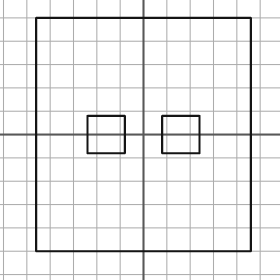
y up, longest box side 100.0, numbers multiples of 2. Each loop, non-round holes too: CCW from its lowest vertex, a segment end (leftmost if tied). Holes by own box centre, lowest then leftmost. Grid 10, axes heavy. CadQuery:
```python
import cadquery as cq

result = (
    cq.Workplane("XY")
    .moveTo(-46.0, -50.0)
    .lineTo(46.0, -50.0)
    .lineTo(46.0, 50.0)
    .lineTo(-46.0, 50.0)
    .close()
    .moveTo(-24.0, -8.0)
    .lineTo(-8.0, -8.0)
    .lineTo(-8.0, 8.0)
    .lineTo(-24.0, 8.0)
    .close()
    .moveTo(8.0, -8.0)
    .lineTo(24.0, -8.0)
    .lineTo(24.0, 8.0)
    .lineTo(8.0, 8.0)
    .close()
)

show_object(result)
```